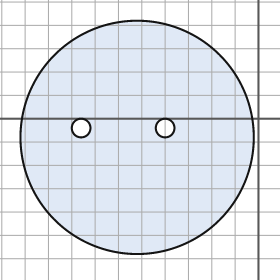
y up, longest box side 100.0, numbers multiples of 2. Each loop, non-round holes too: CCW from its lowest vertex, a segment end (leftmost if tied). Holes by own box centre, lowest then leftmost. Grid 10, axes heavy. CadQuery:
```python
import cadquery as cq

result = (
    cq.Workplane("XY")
    .moveTo(-52.0, -8.0)
    .circle(50.0)
    .moveTo(-76.0, -4.0)
    .circle(4.0)
    .moveTo(-40.0, -4.0)
    .circle(4.0)
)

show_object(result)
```